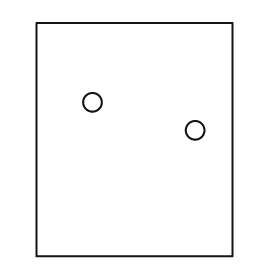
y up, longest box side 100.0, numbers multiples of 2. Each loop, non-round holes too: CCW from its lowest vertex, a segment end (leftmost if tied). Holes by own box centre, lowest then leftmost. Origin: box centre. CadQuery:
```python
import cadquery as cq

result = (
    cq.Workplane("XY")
    .moveTo(-42.0, -50.0)
    .lineTo(42.0, -50.0)
    .lineTo(42.0, 50.0)
    .lineTo(-42.0, 50.0)
    .close()
    .moveTo(26.0, 4.0)
    .circle(4.0)
    .moveTo(-18.0, 16.0)
    .circle(4.0)
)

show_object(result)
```